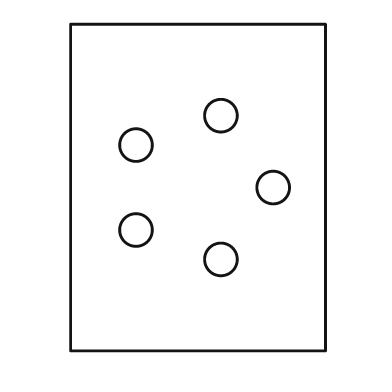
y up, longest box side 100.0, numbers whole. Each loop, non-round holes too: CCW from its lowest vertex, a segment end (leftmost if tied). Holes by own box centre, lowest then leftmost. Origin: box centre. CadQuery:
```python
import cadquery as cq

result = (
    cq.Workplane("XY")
    .moveTo(-39.0, -50.0)
    .lineTo(39.0, -50.0)
    .lineTo(39.0, 50.0)
    .lineTo(-39.0, 50.0)
    .close()
    .moveTo(7.0, -22.0)
    .circle(5.0)
    .moveTo(-19.0, -13.0)
    .circle(5.0)
    .moveTo(23.0, 0.0)
    .circle(5.0)
    .moveTo(-19.0, 13.0)
    .circle(5.0)
    .moveTo(7.0, 22.0)
    .circle(5.0)
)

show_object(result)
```